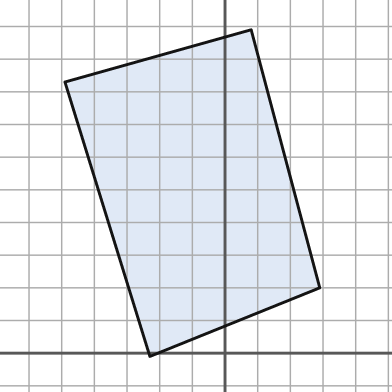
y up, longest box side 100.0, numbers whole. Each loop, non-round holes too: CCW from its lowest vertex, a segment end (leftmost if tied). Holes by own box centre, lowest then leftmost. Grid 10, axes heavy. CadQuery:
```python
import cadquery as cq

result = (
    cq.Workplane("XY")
    .moveTo(-23.0, -1.0)
    .lineTo(29.0, 20.0)
    .lineTo(8.0, 99.0)
    .lineTo(-49.0, 83.0)
    .close()
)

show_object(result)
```